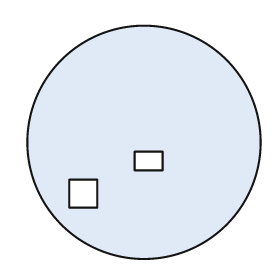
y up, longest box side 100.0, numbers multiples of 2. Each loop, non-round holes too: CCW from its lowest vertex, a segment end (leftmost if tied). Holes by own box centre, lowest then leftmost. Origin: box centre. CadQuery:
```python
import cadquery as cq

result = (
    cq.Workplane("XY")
    .moveTo(0.0, 0.0)
    .circle(50.0)
    .moveTo(-32.0, -28.0)
    .lineTo(-20.0, -28.0)
    .lineTo(-20.0, -16.0)
    .lineTo(-32.0, -16.0)
    .close()
    .moveTo(-4.0, -12.0)
    .lineTo(8.0, -12.0)
    .lineTo(8.0, -4.0)
    .lineTo(-4.0, -4.0)
    .close()
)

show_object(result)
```